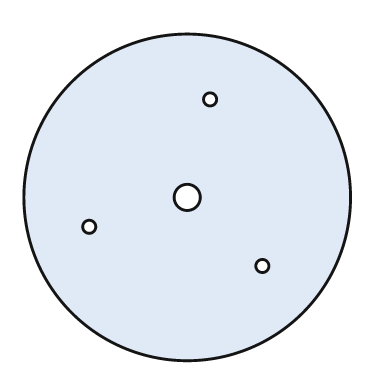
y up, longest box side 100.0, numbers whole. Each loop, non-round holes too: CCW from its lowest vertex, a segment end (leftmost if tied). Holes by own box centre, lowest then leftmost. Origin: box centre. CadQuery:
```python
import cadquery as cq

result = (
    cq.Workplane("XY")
    .moveTo(0.0, 0.0)
    .circle(50.0)
    .moveTo(23.0, -21.0)
    .circle(2.0)
    .moveTo(-30.0, -9.0)
    .circle(2.0)
    .moveTo(0.0, 0.0)
    .circle(4.0)
    .moveTo(7.0, 30.0)
    .circle(2.0)
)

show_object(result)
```